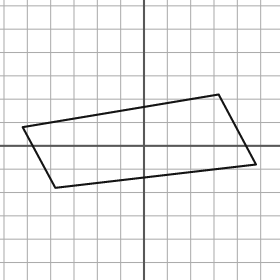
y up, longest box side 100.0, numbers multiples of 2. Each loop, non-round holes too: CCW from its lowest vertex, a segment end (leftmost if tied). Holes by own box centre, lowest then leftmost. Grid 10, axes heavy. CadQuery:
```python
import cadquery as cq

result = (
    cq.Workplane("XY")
    .moveTo(-38.0, -18.0)
    .lineTo(48.0, -8.0)
    .lineTo(32.0, 22.0)
    .lineTo(-52.0, 8.0)
    .close()
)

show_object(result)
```